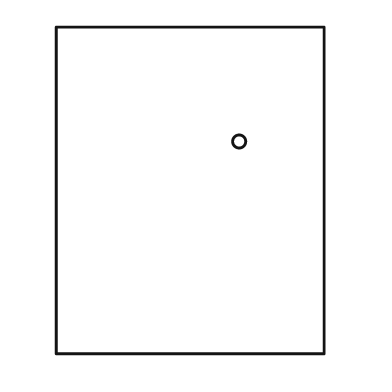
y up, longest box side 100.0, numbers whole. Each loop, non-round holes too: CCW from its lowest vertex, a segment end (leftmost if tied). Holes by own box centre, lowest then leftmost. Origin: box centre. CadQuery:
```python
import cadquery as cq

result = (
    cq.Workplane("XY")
    .moveTo(-41.0, -50.0)
    .lineTo(41.0, -50.0)
    .lineTo(41.0, 50.0)
    .lineTo(-41.0, 50.0)
    .close()
    .moveTo(15.0, 15.0)
    .circle(2.0)
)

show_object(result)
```